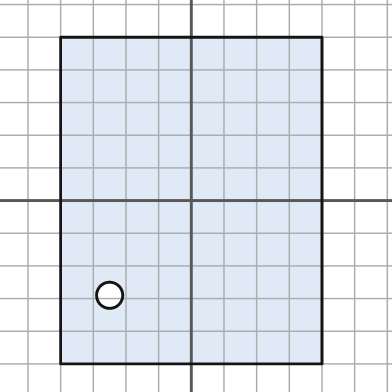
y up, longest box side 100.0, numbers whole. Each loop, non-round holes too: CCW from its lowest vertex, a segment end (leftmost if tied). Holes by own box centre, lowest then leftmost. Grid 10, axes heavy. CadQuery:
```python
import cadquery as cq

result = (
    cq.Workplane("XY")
    .moveTo(-40.0, -50.0)
    .lineTo(40.0, -50.0)
    .lineTo(40.0, 50.0)
    .lineTo(-40.0, 50.0)
    .close()
    .moveTo(-25.0, -29.0)
    .circle(4.0)
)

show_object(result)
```